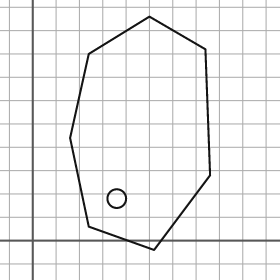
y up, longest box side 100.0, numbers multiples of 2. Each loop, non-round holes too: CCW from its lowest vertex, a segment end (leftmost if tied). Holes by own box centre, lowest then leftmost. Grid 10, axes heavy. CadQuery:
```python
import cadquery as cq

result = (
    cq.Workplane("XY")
    .moveTo(52.0, -4.0)
    .lineTo(76.0, 28.0)
    .lineTo(74.0, 82.0)
    .lineTo(50.0, 96.0)
    .lineTo(24.0, 80.0)
    .lineTo(16.0, 44.0)
    .lineTo(24.0, 6.0)
    .close()
    .moveTo(36.0, 18.0)
    .circle(4.0)
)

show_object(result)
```